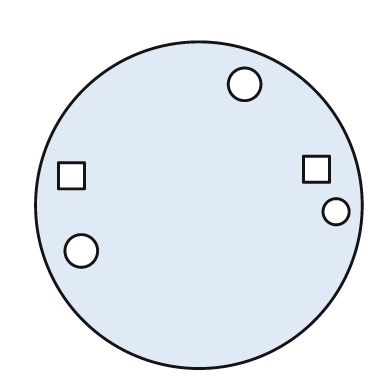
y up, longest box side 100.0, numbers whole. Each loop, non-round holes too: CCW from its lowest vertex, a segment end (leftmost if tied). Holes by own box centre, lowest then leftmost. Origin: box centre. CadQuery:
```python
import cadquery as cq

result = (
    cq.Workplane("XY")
    .moveTo(0.0, 0.0)
    .circle(50.0)
    .moveTo(-36.0, -14.0)
    .circle(5.0)
    .moveTo(42.0, -2.0)
    .circle(4.0)
    .moveTo(-43.0, 5.0)
    .lineTo(-35.0, 5.0)
    .lineTo(-35.0, 13.0)
    .lineTo(-43.0, 13.0)
    .close()
    .moveTo(32.0, 7.0)
    .lineTo(40.0, 7.0)
    .lineTo(40.0, 15.0)
    .lineTo(32.0, 15.0)
    .close()
    .moveTo(14.0, 37.0)
    .circle(5.0)
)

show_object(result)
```